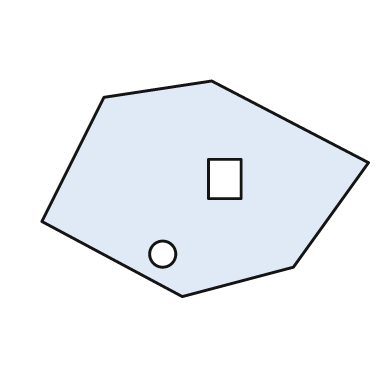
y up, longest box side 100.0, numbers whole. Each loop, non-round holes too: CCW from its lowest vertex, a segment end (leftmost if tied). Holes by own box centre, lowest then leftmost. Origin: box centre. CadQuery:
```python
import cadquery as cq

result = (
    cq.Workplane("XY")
    .moveTo(-7.0, -33.0)
    .lineTo(27.0, -24.0)
    .lineTo(50.0, 8.0)
    .lineTo(2.0, 33.0)
    .lineTo(-31.0, 28.0)
    .lineTo(-50.0, -10.0)
    .close()
    .moveTo(-13.0, -20.0)
    .circle(4.0)
    .moveTo(1.0, -3.0)
    .lineTo(11.0, -3.0)
    .lineTo(11.0, 9.0)
    .lineTo(1.0, 9.0)
    .close()
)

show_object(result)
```